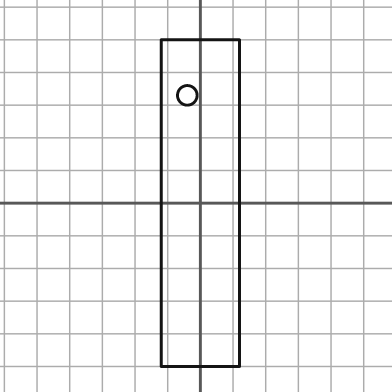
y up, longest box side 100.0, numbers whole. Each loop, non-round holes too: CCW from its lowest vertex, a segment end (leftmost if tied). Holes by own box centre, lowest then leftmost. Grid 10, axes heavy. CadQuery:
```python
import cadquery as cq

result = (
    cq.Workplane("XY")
    .moveTo(-12.0, -50.0)
    .lineTo(12.0, -50.0)
    .lineTo(12.0, 50.0)
    .lineTo(-12.0, 50.0)
    .close()
    .moveTo(-4.0, 33.0)
    .circle(3.0)
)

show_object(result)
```